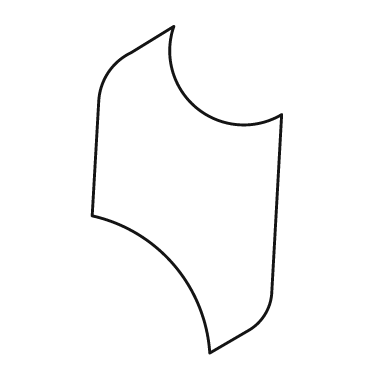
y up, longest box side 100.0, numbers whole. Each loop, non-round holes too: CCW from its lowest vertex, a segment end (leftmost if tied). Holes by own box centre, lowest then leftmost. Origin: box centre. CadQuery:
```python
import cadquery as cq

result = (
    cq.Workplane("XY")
    .moveTo(7.0, -50.0)
    .lineTo(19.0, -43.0)
    .threePointArc((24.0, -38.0), (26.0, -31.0))
    .lineTo(29.0, 23.0)
    .threePointArc((3.0, 25.0), (-4.0, 50.0))
    .lineTo(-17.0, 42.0)
    .threePointArc((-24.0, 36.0), (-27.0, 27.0))
    .lineTo(-29.0, -8.0)
    .threePointArc((-4.0, -23.0), (7.0, -50.0))
    .close()
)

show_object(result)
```